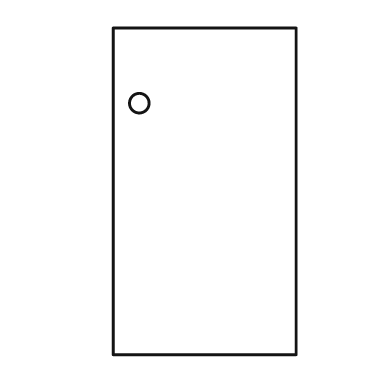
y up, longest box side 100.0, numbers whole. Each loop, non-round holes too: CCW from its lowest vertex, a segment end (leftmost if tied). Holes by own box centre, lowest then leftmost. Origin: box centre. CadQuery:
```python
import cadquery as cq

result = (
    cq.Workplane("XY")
    .moveTo(-28.0, -50.0)
    .lineTo(28.0, -50.0)
    .lineTo(28.0, 50.0)
    .lineTo(-28.0, 50.0)
    .close()
    .moveTo(-20.0, 27.0)
    .circle(3.0)
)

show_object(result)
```